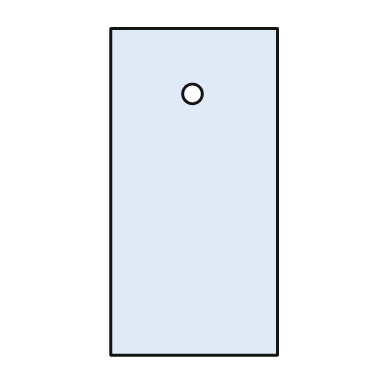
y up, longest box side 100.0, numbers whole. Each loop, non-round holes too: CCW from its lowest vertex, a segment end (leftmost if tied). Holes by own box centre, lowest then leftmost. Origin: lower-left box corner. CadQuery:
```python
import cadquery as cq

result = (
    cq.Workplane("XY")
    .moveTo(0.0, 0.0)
    .lineTo(51.0, 0.0)
    .lineTo(51.0, 100.0)
    .lineTo(0.0, 100.0)
    .close()
    .moveTo(25.0, 80.0)
    .circle(3.0)
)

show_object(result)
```